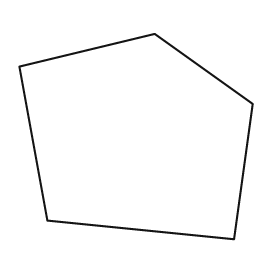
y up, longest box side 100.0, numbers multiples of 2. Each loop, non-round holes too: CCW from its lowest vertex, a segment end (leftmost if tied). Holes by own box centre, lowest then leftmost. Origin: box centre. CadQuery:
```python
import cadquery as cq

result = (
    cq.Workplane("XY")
    .moveTo(42.0, -44.0)
    .lineTo(50.0, 14.0)
    .lineTo(8.0, 44.0)
    .lineTo(-50.0, 30.0)
    .lineTo(-38.0, -36.0)
    .close()
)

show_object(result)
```